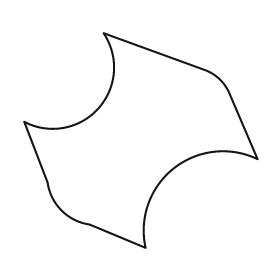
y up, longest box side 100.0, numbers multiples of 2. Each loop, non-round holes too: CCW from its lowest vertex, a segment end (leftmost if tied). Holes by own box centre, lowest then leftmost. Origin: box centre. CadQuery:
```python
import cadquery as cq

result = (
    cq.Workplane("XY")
    .moveTo(2.0, -46.0)
    .threePointArc((14.0, -12.0), (50.0, -8.0))
    .lineTo(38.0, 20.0)
    .threePointArc((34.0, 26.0), (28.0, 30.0))
    .lineTo(-16.0, 46.0)
    .threePointArc((-18.0, 14.0), (-50.0, 8.0))
    .lineTo(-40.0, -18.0)
    .threePointArc((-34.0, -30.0), (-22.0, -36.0))
    .close()
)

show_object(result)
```